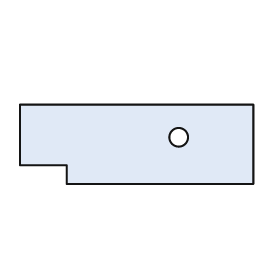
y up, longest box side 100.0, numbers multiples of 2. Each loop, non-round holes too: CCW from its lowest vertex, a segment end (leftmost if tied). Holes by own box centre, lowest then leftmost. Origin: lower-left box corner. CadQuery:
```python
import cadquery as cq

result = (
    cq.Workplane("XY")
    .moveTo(20.0, 0.0)
    .lineTo(100.0, 0.0)
    .lineTo(100.0, 34.0)
    .lineTo(0.0, 34.0)
    .lineTo(0.0, 8.0)
    .lineTo(20.0, 8.0)
    .close()
    .moveTo(68.0, 20.0)
    .circle(4.0)
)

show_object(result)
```